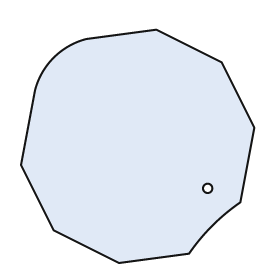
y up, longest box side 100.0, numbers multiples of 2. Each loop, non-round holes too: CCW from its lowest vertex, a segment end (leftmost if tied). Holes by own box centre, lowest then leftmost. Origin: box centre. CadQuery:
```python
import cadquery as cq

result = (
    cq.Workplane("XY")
    .moveTo(-8.0, -50.0)
    .lineTo(22.0, -46.0)
    .threePointArc((32.0, -34.0), (44.0, -24.0))
    .lineTo(50.0, 8.0)
    .lineTo(36.0, 36.0)
    .lineTo(8.0, 50.0)
    .lineTo(-22.0, 46.0)
    .threePointArc((-36.0, 38.0), (-44.0, 24.0))
    .lineTo(-50.0, -8.0)
    .lineTo(-36.0, -36.0)
    .close()
    .moveTo(30.0, -18.0)
    .circle(2.0)
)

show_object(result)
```